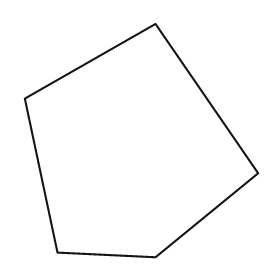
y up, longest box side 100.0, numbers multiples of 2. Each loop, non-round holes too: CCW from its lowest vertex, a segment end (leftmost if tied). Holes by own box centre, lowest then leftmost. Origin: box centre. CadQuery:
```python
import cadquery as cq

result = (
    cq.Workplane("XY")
    .moveTo(6.0, -50.0)
    .lineTo(50.0, -14.0)
    .lineTo(6.0, 50.0)
    .lineTo(-50.0, 18.0)
    .lineTo(-36.0, -48.0)
    .close()
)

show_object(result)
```